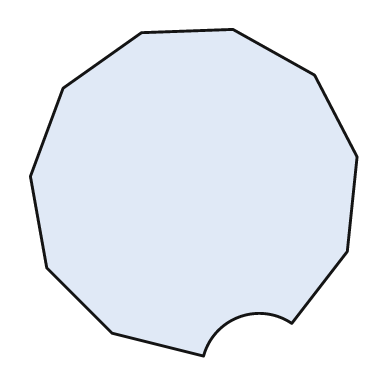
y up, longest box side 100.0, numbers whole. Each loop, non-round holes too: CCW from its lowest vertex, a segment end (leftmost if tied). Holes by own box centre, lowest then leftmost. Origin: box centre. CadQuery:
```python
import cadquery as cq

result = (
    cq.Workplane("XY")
    .moveTo(3.0, -50.0)
    .threePointArc((14.0, -38.0), (30.0, -40.0))
    .lineTo(47.0, -18.0)
    .lineTo(50.0, 11.0)
    .lineTo(37.0, 36.0)
    .lineTo(12.0, 50.0)
    .lineTo(-16.0, 49.0)
    .lineTo(-40.0, 32.0)
    .lineTo(-50.0, 5.0)
    .lineTo(-45.0, -23.0)
    .lineTo(-25.0, -43.0)
    .close()
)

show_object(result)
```